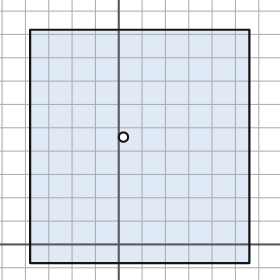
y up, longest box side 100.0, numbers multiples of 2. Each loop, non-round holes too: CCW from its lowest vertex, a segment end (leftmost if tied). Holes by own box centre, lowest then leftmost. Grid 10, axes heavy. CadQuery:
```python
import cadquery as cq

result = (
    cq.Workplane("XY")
    .moveTo(-38.0, -8.0)
    .lineTo(56.0, -8.0)
    .lineTo(56.0, 92.0)
    .lineTo(-38.0, 92.0)
    .close()
    .moveTo(2.0, 46.0)
    .circle(2.0)
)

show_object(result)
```